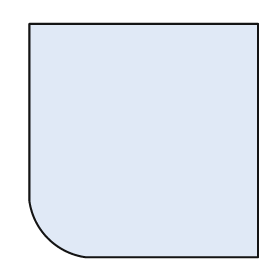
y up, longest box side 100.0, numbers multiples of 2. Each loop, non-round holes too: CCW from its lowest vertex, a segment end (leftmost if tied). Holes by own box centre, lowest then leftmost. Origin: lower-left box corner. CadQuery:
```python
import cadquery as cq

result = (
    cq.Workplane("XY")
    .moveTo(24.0, 0.0)
    .lineTo(98.0, 0.0)
    .lineTo(98.0, 100.0)
    .lineTo(0.0, 100.0)
    .lineTo(0.0, 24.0)
    .threePointArc((8.0, 8.0), (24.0, 0.0))
    .close()
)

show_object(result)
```